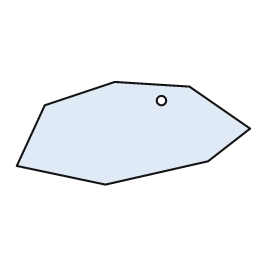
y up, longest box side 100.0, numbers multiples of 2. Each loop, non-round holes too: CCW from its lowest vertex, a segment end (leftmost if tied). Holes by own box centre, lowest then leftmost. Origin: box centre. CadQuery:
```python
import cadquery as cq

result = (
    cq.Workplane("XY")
    .moveTo(-12.0, -22.0)
    .lineTo(32.0, -12.0)
    .lineTo(50.0, 2.0)
    .lineTo(24.0, 20.0)
    .lineTo(-8.0, 22.0)
    .lineTo(-38.0, 12.0)
    .lineTo(-50.0, -14.0)
    .close()
    .moveTo(12.0, 14.0)
    .circle(2.0)
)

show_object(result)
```